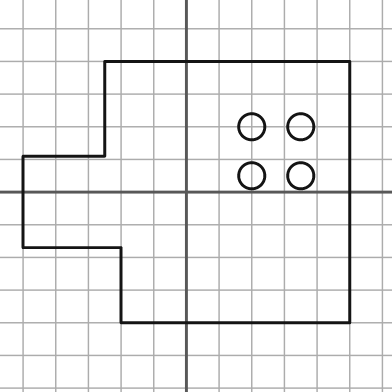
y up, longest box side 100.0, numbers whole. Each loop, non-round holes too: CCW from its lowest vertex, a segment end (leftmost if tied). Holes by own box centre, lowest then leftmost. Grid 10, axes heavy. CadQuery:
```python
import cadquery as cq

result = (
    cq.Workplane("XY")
    .moveTo(-20.0, -40.0)
    .lineTo(50.0, -40.0)
    .lineTo(50.0, 40.0)
    .lineTo(-25.0, 40.0)
    .lineTo(-25.0, 11.0)
    .lineTo(-50.0, 11.0)
    .lineTo(-50.0, -17.0)
    .lineTo(-20.0, -17.0)
    .close()
    .moveTo(20.0, 5.0)
    .circle(4.0)
    .moveTo(35.0, 5.0)
    .circle(4.0)
    .moveTo(20.0, 20.0)
    .circle(4.0)
    .moveTo(35.0, 20.0)
    .circle(4.0)
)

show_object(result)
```